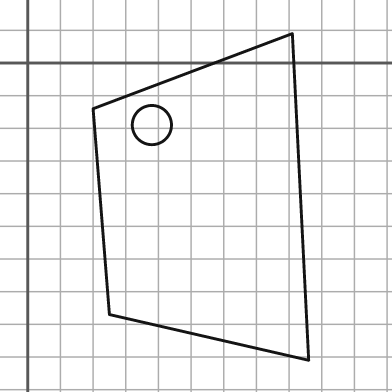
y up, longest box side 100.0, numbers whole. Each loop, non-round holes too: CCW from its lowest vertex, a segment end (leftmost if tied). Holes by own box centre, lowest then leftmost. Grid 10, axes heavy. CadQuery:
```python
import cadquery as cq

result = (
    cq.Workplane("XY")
    .moveTo(86.0, -91.0)
    .lineTo(81.0, 9.0)
    .lineTo(20.0, -14.0)
    .lineTo(25.0, -77.0)
    .close()
    .moveTo(38.0, -19.0)
    .circle(6.0)
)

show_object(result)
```